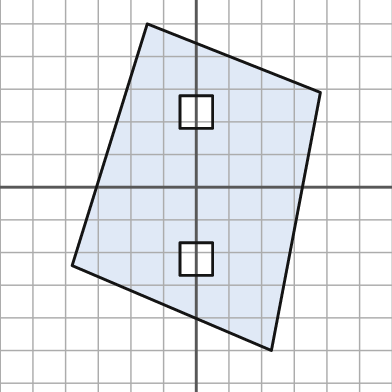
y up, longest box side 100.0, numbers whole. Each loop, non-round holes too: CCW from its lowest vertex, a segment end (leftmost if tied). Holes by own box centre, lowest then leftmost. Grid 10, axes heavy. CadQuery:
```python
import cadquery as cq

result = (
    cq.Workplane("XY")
    .moveTo(23.0, -50.0)
    .lineTo(38.0, 29.0)
    .lineTo(-15.0, 50.0)
    .lineTo(-38.0, -24.0)
    .close()
    .moveTo(-5.0, -27.0)
    .lineTo(5.0, -27.0)
    .lineTo(5.0, -17.0)
    .lineTo(-5.0, -17.0)
    .close()
    .moveTo(-5.0, 18.0)
    .lineTo(5.0, 18.0)
    .lineTo(5.0, 28.0)
    .lineTo(-5.0, 28.0)
    .close()
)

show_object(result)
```